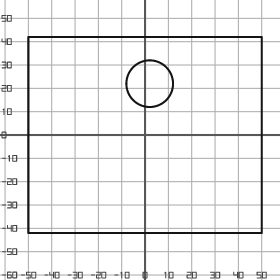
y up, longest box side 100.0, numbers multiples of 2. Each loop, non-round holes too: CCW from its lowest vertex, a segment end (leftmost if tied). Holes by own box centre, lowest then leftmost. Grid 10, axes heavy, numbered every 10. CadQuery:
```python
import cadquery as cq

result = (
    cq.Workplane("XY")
    .moveTo(-50.0, -42.0)
    .lineTo(50.0, -42.0)
    .lineTo(50.0, 42.0)
    .lineTo(-50.0, 42.0)
    .close()
    .moveTo(2.0, 22.0)
    .circle(10.0)
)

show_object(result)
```